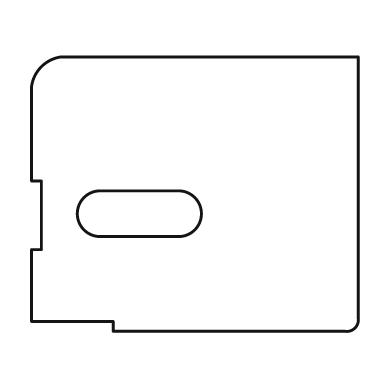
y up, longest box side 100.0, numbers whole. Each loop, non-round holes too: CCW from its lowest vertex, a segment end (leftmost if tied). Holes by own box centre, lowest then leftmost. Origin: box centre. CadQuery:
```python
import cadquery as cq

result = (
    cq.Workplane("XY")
    .moveTo(-25.0, -42.0)
    .lineTo(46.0, -42.0)
    .threePointArc((49.0, -41.0), (50.0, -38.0))
    .lineTo(50.0, 42.0)
    .lineTo(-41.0, 42.0)
    .threePointArc((-47.0, 39.0), (-50.0, 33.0))
    .lineTo(-50.0, 4.0)
    .lineTo(-47.0, 4.0)
    .lineTo(-47.0, -17.0)
    .lineTo(-50.0, -17.0)
    .lineTo(-50.0, -39.0)
    .lineTo(-25.0, -39.0)
    .close()
    .moveTo(-29.0, -13.0)
    .lineTo(-5.0, -13.0)
    .threePointArc((2.0, -6.0), (-5.0, 1.0))
    .lineTo(-29.0, 1.0)
    .threePointArc((-36.0, -6.0), (-29.0, -13.0))
    .close()
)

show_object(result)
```